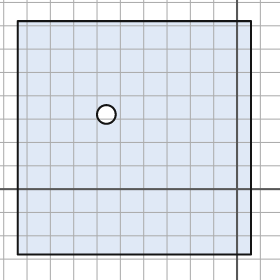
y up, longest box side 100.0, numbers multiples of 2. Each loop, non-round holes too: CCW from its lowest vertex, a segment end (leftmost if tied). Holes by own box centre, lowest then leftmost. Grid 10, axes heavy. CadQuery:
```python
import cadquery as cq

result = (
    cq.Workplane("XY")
    .moveTo(-94.0, -28.0)
    .lineTo(6.0, -28.0)
    .lineTo(6.0, 72.0)
    .lineTo(-94.0, 72.0)
    .close()
    .moveTo(-56.0, 32.0)
    .circle(4.0)
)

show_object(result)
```